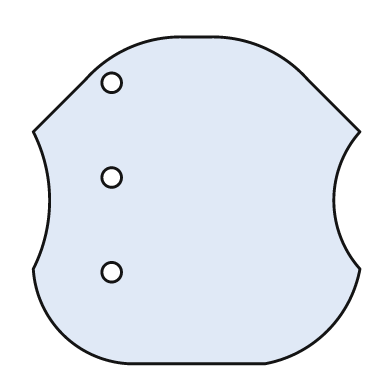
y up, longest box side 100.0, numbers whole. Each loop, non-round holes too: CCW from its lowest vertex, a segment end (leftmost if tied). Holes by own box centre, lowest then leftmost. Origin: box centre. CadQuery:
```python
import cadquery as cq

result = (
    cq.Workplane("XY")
    .moveTo(-21.0, -50.0)
    .lineTo(21.0, -50.0)
    .threePointArc((40.0, -40.0), (50.0, -21.0))
    .threePointArc((42.0, 0.0), (50.0, 21.0))
    .lineTo(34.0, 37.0)
    .threePointArc((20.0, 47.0), (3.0, 50.0))
    .lineTo(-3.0, 50.0)
    .threePointArc((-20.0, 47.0), (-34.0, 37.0))
    .lineTo(-50.0, 21.0)
    .threePointArc((-45.0, 0.0), (-50.0, -21.0))
    .threePointArc((-41.0, -41.0), (-21.0, -50.0))
    .close()
    .moveTo(-26.0, -22.0)
    .circle(3.0)
    .moveTo(-26.0, 7.0)
    .circle(3.0)
    .moveTo(-26.0, 36.0)
    .circle(3.0)
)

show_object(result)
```